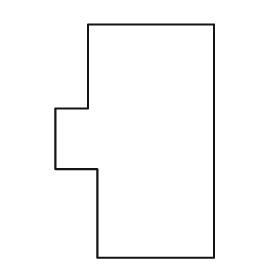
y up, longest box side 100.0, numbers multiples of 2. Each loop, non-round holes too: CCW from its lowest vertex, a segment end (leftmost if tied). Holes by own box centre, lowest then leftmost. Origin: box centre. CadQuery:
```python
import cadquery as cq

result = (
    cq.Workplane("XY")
    .moveTo(-16.0, -50.0)
    .lineTo(34.0, -50.0)
    .lineTo(34.0, 50.0)
    .lineTo(-20.0, 50.0)
    .lineTo(-20.0, 14.0)
    .lineTo(-34.0, 14.0)
    .lineTo(-34.0, -12.0)
    .lineTo(-16.0, -12.0)
    .close()
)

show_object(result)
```